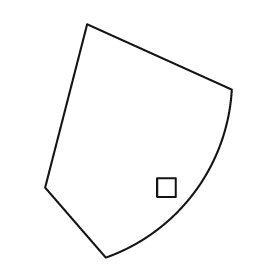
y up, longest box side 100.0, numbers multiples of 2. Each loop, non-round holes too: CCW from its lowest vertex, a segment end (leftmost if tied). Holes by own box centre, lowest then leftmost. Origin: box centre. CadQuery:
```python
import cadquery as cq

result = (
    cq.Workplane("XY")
    .moveTo(-14.0, -50.0)
    .threePointArc((24.0, -22.0), (40.0, 22.0))
    .lineTo(-22.0, 50.0)
    .lineTo(-40.0, -20.0)
    .close()
    .moveTo(8.0, -24.0)
    .lineTo(16.0, -24.0)
    .lineTo(16.0, -16.0)
    .lineTo(8.0, -16.0)
    .close()
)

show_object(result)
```